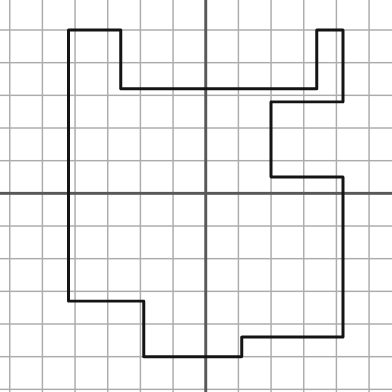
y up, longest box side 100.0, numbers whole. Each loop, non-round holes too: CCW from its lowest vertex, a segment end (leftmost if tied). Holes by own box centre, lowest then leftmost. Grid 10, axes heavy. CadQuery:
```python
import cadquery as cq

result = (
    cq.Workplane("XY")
    .moveTo(-19.0, -50.0)
    .lineTo(11.0, -50.0)
    .lineTo(11.0, -44.0)
    .lineTo(42.0, -44.0)
    .lineTo(42.0, 5.0)
    .lineTo(20.0, 5.0)
    .lineTo(20.0, 28.0)
    .lineTo(42.0, 28.0)
    .lineTo(42.0, 50.0)
    .lineTo(34.0, 50.0)
    .lineTo(34.0, 32.0)
    .lineTo(-26.0, 32.0)
    .lineTo(-26.0, 50.0)
    .lineTo(-42.0, 50.0)
    .lineTo(-42.0, -33.0)
    .lineTo(-19.0, -33.0)
    .close()
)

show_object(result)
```